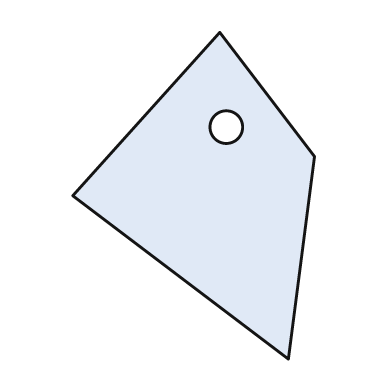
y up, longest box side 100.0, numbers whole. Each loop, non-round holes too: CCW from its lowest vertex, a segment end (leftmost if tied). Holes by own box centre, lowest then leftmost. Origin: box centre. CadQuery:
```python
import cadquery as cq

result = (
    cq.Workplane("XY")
    .moveTo(29.0, -50.0)
    .lineTo(37.0, 12.0)
    .lineTo(8.0, 50.0)
    .lineTo(-37.0, 0.0)
    .close()
    .moveTo(10.0, 21.0)
    .circle(5.0)
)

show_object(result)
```